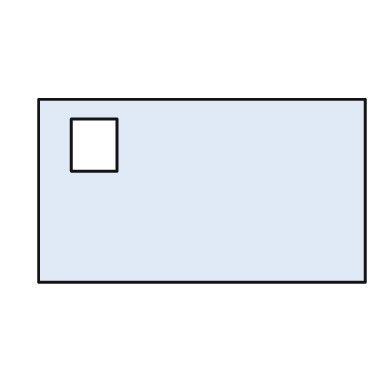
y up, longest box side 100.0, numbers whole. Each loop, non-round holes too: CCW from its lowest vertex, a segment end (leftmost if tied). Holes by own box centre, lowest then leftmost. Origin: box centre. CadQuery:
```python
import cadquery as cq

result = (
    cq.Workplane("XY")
    .moveTo(-50.0, -28.0)
    .lineTo(50.0, -28.0)
    .lineTo(50.0, 28.0)
    .lineTo(-50.0, 28.0)
    .close()
    .moveTo(-40.0, 6.0)
    .lineTo(-26.0, 6.0)
    .lineTo(-26.0, 22.0)
    .lineTo(-40.0, 22.0)
    .close()
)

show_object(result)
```